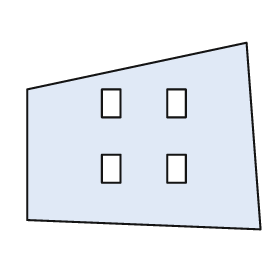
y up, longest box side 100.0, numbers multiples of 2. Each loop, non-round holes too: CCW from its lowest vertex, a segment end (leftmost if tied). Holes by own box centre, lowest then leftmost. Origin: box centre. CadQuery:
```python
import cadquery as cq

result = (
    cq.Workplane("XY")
    .moveTo(50.0, -40.0)
    .lineTo(44.0, 40.0)
    .lineTo(-50.0, 20.0)
    .lineTo(-50.0, -36.0)
    .close()
    .moveTo(-18.0, -20.0)
    .lineTo(-10.0, -20.0)
    .lineTo(-10.0, -8.0)
    .lineTo(-18.0, -8.0)
    .close()
    .moveTo(10.0, -20.0)
    .lineTo(18.0, -20.0)
    .lineTo(18.0, -8.0)
    .lineTo(10.0, -8.0)
    .close()
    .moveTo(-18.0, 8.0)
    .lineTo(-10.0, 8.0)
    .lineTo(-10.0, 20.0)
    .lineTo(-18.0, 20.0)
    .close()
    .moveTo(10.0, 8.0)
    .lineTo(18.0, 8.0)
    .lineTo(18.0, 20.0)
    .lineTo(10.0, 20.0)
    .close()
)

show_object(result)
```